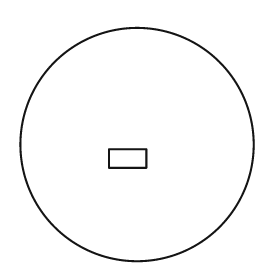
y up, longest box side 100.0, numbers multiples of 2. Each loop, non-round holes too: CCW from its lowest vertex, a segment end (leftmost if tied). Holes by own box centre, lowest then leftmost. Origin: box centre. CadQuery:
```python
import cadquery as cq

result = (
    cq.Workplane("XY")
    .moveTo(0.0, 0.0)
    .circle(50.0)
    .moveTo(-12.0, -10.0)
    .lineTo(4.0, -10.0)
    .lineTo(4.0, -2.0)
    .lineTo(-12.0, -2.0)
    .close()
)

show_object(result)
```